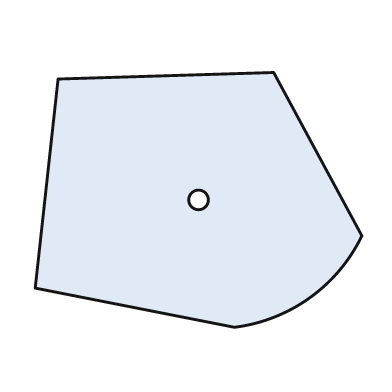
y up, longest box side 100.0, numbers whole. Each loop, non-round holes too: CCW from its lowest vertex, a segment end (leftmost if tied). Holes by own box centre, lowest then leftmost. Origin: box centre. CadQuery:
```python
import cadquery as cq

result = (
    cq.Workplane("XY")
    .moveTo(11.0, -39.0)
    .threePointArc((34.0, -30.0), (50.0, -11.0))
    .lineTo(23.0, 39.0)
    .lineTo(-43.0, 37.0)
    .lineTo(-50.0, -27.0)
    .close()
    .moveTo(0.0, 0.0)
    .circle(3.0)
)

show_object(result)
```